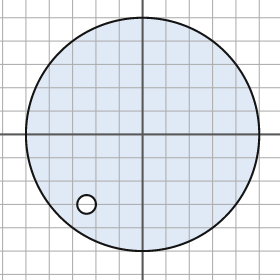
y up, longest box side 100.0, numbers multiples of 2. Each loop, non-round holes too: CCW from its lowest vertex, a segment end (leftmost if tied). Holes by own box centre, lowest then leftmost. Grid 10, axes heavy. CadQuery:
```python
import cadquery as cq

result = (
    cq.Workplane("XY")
    .moveTo(0.0, 0.0)
    .circle(50.0)
    .moveTo(-24.0, -30.0)
    .circle(4.0)
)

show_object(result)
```